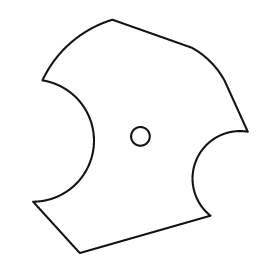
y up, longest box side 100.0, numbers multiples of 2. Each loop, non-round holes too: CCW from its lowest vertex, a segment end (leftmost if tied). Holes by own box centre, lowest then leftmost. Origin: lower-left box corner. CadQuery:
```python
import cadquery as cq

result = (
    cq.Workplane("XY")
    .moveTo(20.0, 0.0)
    .lineTo(76.0, 16.0)
    .threePointArc((70.0, 40.0), (92.0, 52.0))
    .lineTo(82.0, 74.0)
    .threePointArc((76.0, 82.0), (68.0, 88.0))
    .lineTo(34.0, 100.0)
    .threePointArc((16.0, 90.0), (4.0, 74.0))
    .threePointArc((26.0, 46.0), (0.0, 22.0))
    .close()
    .moveTo(46.0, 50.0)
    .circle(4.0)
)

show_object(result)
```